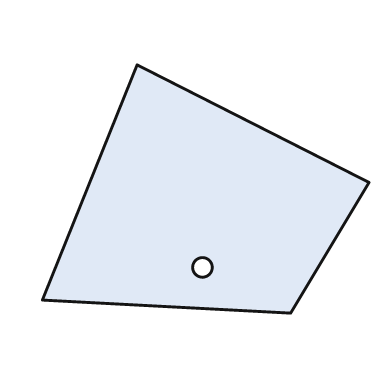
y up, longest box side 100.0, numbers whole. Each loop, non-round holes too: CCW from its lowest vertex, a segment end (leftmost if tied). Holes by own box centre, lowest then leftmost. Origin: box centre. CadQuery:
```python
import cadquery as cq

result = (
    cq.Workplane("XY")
    .moveTo(26.0, -38.0)
    .lineTo(50.0, 2.0)
    .lineTo(-21.0, 38.0)
    .lineTo(-50.0, -34.0)
    .close()
    .moveTo(-1.0, -24.0)
    .circle(3.0)
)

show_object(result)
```